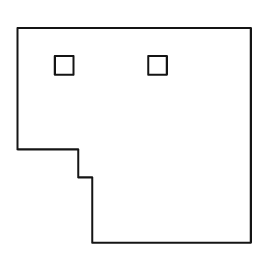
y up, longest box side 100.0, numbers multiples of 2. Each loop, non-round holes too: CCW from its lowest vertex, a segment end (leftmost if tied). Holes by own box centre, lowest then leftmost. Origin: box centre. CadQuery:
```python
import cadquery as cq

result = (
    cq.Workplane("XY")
    .moveTo(-18.0, -46.0)
    .lineTo(50.0, -46.0)
    .lineTo(50.0, 46.0)
    .lineTo(-50.0, 46.0)
    .lineTo(-50.0, -6.0)
    .lineTo(-24.0, -6.0)
    .lineTo(-24.0, -18.0)
    .lineTo(-18.0, -18.0)
    .close()
    .moveTo(-34.0, 26.0)
    .lineTo(-26.0, 26.0)
    .lineTo(-26.0, 34.0)
    .lineTo(-34.0, 34.0)
    .close()
    .moveTo(6.0, 26.0)
    .lineTo(14.0, 26.0)
    .lineTo(14.0, 34.0)
    .lineTo(6.0, 34.0)
    .close()
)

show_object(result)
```